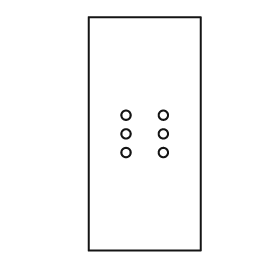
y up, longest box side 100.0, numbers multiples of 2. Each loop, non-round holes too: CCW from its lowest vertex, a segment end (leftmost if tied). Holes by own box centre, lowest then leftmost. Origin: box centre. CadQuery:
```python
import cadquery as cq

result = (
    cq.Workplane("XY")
    .moveTo(-24.0, -50.0)
    .lineTo(24.0, -50.0)
    .lineTo(24.0, 50.0)
    .lineTo(-24.0, 50.0)
    .close()
    .moveTo(-8.0, -8.0)
    .circle(2.0)
    .moveTo(8.0, -8.0)
    .circle(2.0)
    .moveTo(-8.0, 0.0)
    .circle(2.0)
    .moveTo(8.0, 0.0)
    .circle(2.0)
    .moveTo(-8.0, 8.0)
    .circle(2.0)
    .moveTo(8.0, 8.0)
    .circle(2.0)
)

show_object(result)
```